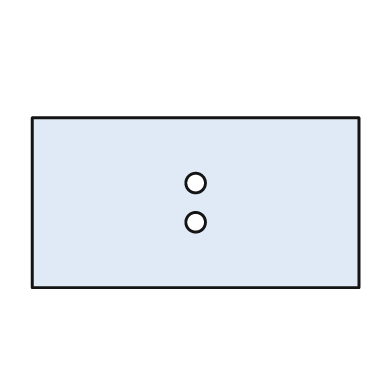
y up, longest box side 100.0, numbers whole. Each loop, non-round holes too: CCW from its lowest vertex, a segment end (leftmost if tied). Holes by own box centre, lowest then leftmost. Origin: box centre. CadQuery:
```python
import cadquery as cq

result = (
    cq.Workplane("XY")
    .moveTo(-50.0, -26.0)
    .lineTo(50.0, -26.0)
    .lineTo(50.0, 26.0)
    .lineTo(-50.0, 26.0)
    .close()
    .moveTo(0.0, -6.0)
    .circle(3.0)
    .moveTo(0.0, 6.0)
    .circle(3.0)
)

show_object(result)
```